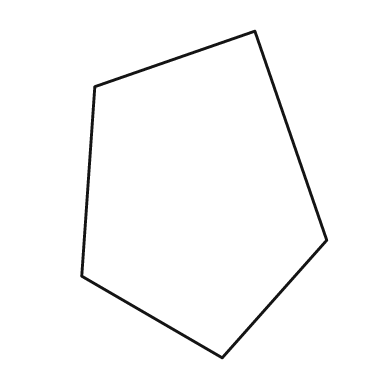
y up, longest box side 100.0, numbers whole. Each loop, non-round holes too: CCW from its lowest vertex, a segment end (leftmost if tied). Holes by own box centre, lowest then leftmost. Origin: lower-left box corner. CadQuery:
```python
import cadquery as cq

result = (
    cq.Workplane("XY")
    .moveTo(43.0, 0.0)
    .lineTo(75.0, 36.0)
    .lineTo(53.0, 100.0)
    .lineTo(4.0, 83.0)
    .lineTo(0.0, 25.0)
    .close()
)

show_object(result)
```